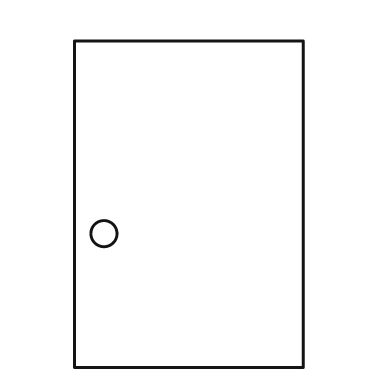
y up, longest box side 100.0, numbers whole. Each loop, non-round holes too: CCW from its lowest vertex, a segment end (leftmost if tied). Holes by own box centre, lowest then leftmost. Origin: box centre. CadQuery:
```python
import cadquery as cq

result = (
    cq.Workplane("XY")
    .moveTo(-35.0, -50.0)
    .lineTo(35.0, -50.0)
    .lineTo(35.0, 50.0)
    .lineTo(-35.0, 50.0)
    .close()
    .moveTo(-26.0, -9.0)
    .circle(4.0)
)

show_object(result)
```